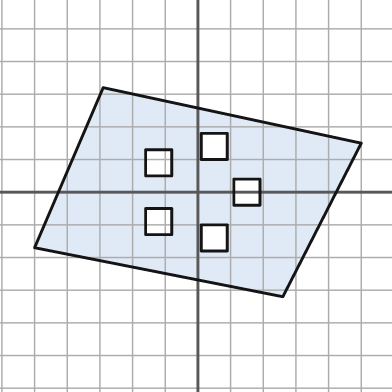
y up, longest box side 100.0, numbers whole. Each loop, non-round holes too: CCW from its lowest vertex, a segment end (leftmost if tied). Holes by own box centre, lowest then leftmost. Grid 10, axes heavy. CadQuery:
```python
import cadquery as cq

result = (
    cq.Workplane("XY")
    .moveTo(26.0, -32.0)
    .lineTo(50.0, 15.0)
    .lineTo(-29.0, 32.0)
    .lineTo(-50.0, -17.0)
    .close()
    .moveTo(1.0, -18.0)
    .lineTo(9.0, -18.0)
    .lineTo(9.0, -10.0)
    .lineTo(1.0, -10.0)
    .close()
    .moveTo(-16.0, -13.0)
    .lineTo(-8.0, -13.0)
    .lineTo(-8.0, -5.0)
    .lineTo(-16.0, -5.0)
    .close()
    .moveTo(11.0, -4.0)
    .lineTo(19.0, -4.0)
    .lineTo(19.0, 4.0)
    .lineTo(11.0, 4.0)
    .close()
    .moveTo(-16.0, 5.0)
    .lineTo(-8.0, 5.0)
    .lineTo(-8.0, 13.0)
    .lineTo(-16.0, 13.0)
    .close()
    .moveTo(1.0, 10.0)
    .lineTo(9.0, 10.0)
    .lineTo(9.0, 18.0)
    .lineTo(1.0, 18.0)
    .close()
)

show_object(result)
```